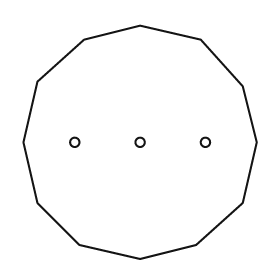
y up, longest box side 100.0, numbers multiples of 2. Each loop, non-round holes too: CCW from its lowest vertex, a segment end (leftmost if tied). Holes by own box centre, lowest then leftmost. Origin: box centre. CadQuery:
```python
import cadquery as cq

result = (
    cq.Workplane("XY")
    .moveTo(0.0, -50.0)
    .lineTo(24.0, -44.0)
    .lineTo(44.0, -26.0)
    .lineTo(50.0, 0.0)
    .lineTo(44.0, 24.0)
    .lineTo(26.0, 44.0)
    .lineTo(0.0, 50.0)
    .lineTo(-24.0, 44.0)
    .lineTo(-44.0, 26.0)
    .lineTo(-50.0, 0.0)
    .lineTo(-44.0, -26.0)
    .lineTo(-26.0, -44.0)
    .close()
    .moveTo(-28.0, 0.0)
    .circle(2.0)
    .moveTo(0.0, 0.0)
    .circle(2.0)
    .moveTo(28.0, 0.0)
    .circle(2.0)
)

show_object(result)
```